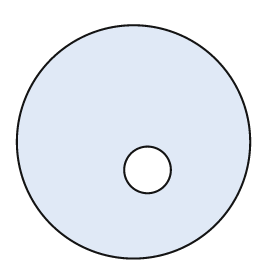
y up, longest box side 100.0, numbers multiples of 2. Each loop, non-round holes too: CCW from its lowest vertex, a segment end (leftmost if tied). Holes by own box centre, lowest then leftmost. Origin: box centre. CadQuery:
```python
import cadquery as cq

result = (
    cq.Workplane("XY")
    .moveTo(0.0, 0.0)
    .circle(50.0)
    .moveTo(6.0, -12.0)
    .circle(10.0)
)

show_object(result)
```